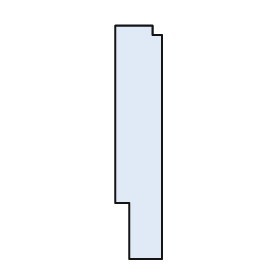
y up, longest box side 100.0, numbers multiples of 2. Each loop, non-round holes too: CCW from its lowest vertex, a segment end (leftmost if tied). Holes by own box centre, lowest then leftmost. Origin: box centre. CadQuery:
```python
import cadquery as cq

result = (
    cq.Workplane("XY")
    .moveTo(-4.0, -50.0)
    .lineTo(10.0, -50.0)
    .lineTo(10.0, 46.0)
    .lineTo(6.0, 46.0)
    .lineTo(6.0, 50.0)
    .lineTo(-10.0, 50.0)
    .lineTo(-10.0, -26.0)
    .lineTo(-4.0, -26.0)
    .close()
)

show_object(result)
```